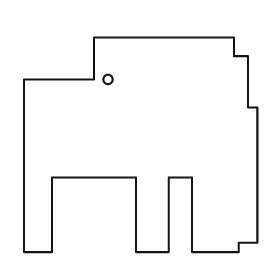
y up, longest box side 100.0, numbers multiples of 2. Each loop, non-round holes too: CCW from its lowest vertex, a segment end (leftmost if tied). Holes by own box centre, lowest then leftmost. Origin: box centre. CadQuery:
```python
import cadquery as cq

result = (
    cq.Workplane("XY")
    .moveTo(-50.0, -46.0)
    .lineTo(-38.0, -46.0)
    .lineTo(-38.0, -14.0)
    .lineTo(-2.0, -14.0)
    .lineTo(-2.0, -46.0)
    .lineTo(12.0, -46.0)
    .lineTo(12.0, -14.0)
    .lineTo(22.0, -14.0)
    .lineTo(22.0, -46.0)
    .lineTo(42.0, -46.0)
    .lineTo(42.0, -42.0)
    .lineTo(50.0, -42.0)
    .lineTo(50.0, 16.0)
    .lineTo(46.0, 16.0)
    .lineTo(46.0, 38.0)
    .lineTo(40.0, 38.0)
    .lineTo(40.0, 46.0)
    .lineTo(-20.0, 46.0)
    .lineTo(-20.0, 28.0)
    .lineTo(-50.0, 28.0)
    .close()
    .moveTo(-14.0, 28.0)
    .circle(2.0)
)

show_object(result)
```